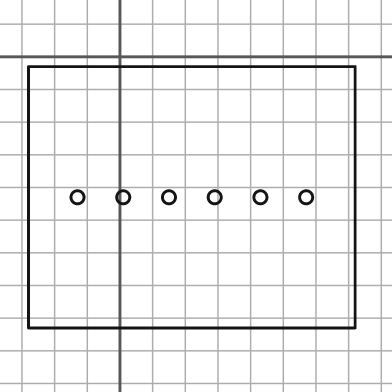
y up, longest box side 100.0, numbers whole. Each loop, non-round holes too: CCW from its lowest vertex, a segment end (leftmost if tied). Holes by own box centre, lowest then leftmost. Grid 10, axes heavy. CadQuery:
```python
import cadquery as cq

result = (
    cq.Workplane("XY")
    .moveTo(-28.0, -83.0)
    .lineTo(72.0, -83.0)
    .lineTo(72.0, -3.0)
    .lineTo(-28.0, -3.0)
    .close()
    .moveTo(-13.0, -43.0)
    .circle(2.0)
    .moveTo(1.0, -43.0)
    .circle(2.0)
    .moveTo(15.0, -43.0)
    .circle(2.0)
    .moveTo(29.0, -43.0)
    .circle(2.0)
    .moveTo(43.0, -43.0)
    .circle(2.0)
    .moveTo(57.0, -43.0)
    .circle(2.0)
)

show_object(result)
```